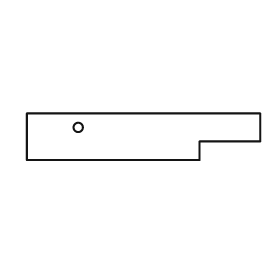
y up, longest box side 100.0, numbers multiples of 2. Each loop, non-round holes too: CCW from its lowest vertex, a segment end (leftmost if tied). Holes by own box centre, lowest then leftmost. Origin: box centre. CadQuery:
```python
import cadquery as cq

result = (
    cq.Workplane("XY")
    .moveTo(-50.0, -10.0)
    .lineTo(24.0, -10.0)
    .lineTo(24.0, -2.0)
    .lineTo(50.0, -2.0)
    .lineTo(50.0, 10.0)
    .lineTo(-50.0, 10.0)
    .close()
    .moveTo(-28.0, 4.0)
    .circle(2.0)
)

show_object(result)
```